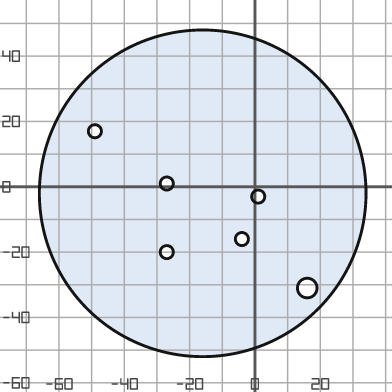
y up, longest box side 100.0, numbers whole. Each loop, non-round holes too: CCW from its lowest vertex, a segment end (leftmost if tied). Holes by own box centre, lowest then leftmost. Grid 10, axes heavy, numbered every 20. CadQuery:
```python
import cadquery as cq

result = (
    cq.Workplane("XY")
    .moveTo(-16.0, -2.0)
    .circle(50.0)
    .moveTo(16.0, -31.0)
    .circle(3.0)
    .moveTo(-27.0, -20.0)
    .circle(2.0)
    .moveTo(-4.0, -16.0)
    .circle(2.0)
    .moveTo(1.0, -3.0)
    .circle(2.0)
    .moveTo(-27.0, 1.0)
    .circle(2.0)
    .moveTo(-49.0, 17.0)
    .circle(2.0)
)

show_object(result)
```